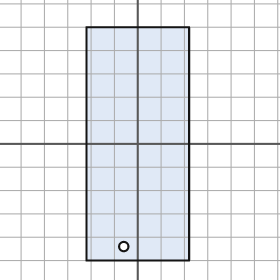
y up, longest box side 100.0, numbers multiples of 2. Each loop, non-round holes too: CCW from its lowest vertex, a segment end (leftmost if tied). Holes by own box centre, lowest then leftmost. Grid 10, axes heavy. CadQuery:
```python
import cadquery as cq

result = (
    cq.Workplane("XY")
    .moveTo(-22.0, -50.0)
    .lineTo(22.0, -50.0)
    .lineTo(22.0, 50.0)
    .lineTo(-22.0, 50.0)
    .close()
    .moveTo(-6.0, -44.0)
    .circle(2.0)
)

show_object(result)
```